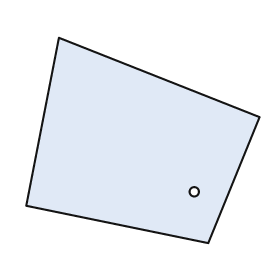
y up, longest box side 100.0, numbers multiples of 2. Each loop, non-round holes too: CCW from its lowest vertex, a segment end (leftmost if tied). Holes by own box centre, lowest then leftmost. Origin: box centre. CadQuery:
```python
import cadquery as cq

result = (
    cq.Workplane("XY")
    .moveTo(28.0, -44.0)
    .lineTo(50.0, 10.0)
    .lineTo(-36.0, 44.0)
    .lineTo(-50.0, -28.0)
    .close()
    .moveTo(22.0, -22.0)
    .circle(2.0)
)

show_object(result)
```